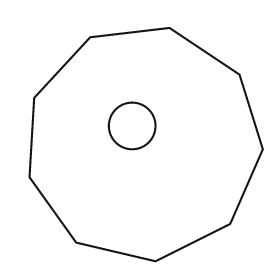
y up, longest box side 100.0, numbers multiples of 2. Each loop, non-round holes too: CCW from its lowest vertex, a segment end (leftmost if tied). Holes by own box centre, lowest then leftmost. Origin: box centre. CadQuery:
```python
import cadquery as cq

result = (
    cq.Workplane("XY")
    .moveTo(4.0, -50.0)
    .lineTo(36.0, -34.0)
    .lineTo(50.0, -2.0)
    .lineTo(40.0, 30.0)
    .lineTo(10.0, 50.0)
    .lineTo(-24.0, 46.0)
    .lineTo(-48.0, 20.0)
    .lineTo(-50.0, -14.0)
    .lineTo(-30.0, -42.0)
    .close()
    .moveTo(-6.0, 8.0)
    .circle(10.0)
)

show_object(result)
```